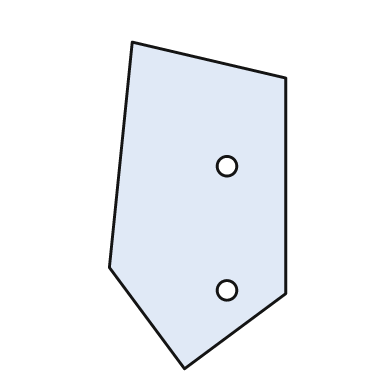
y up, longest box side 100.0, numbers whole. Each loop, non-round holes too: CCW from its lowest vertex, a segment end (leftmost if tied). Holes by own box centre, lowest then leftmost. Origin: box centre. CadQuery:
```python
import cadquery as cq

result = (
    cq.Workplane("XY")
    .moveTo(-4.0, -50.0)
    .lineTo(27.0, -27.0)
    .lineTo(27.0, 39.0)
    .lineTo(-20.0, 50.0)
    .lineTo(-27.0, -19.0)
    .close()
    .moveTo(9.0, -26.0)
    .circle(3.0)
    .moveTo(9.0, 12.0)
    .circle(3.0)
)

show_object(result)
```